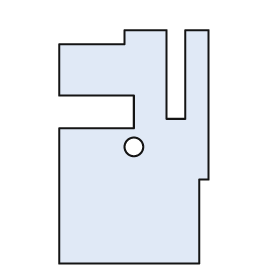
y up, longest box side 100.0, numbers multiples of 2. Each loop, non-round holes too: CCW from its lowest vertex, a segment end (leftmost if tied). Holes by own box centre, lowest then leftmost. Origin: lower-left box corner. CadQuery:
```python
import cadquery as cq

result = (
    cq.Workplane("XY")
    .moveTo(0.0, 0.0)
    .lineTo(60.0, 0.0)
    .lineTo(60.0, 36.0)
    .lineTo(64.0, 36.0)
    .lineTo(64.0, 100.0)
    .lineTo(54.0, 100.0)
    .lineTo(54.0, 62.0)
    .lineTo(46.0, 62.0)
    .lineTo(46.0, 100.0)
    .lineTo(28.0, 100.0)
    .lineTo(28.0, 94.0)
    .lineTo(0.0, 94.0)
    .lineTo(0.0, 72.0)
    .lineTo(32.0, 72.0)
    .lineTo(32.0, 58.0)
    .lineTo(0.0, 58.0)
    .close()
    .moveTo(32.0, 50.0)
    .circle(4.0)
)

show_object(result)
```